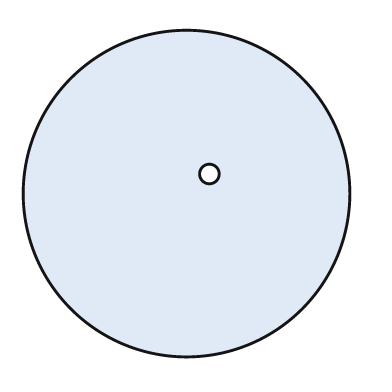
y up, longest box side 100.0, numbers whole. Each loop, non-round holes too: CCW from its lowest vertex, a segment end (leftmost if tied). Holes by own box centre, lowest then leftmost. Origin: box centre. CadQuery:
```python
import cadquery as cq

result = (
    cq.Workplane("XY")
    .moveTo(0.0, 0.0)
    .circle(50.0)
    .moveTo(7.0, 6.0)
    .circle(3.0)
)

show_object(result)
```